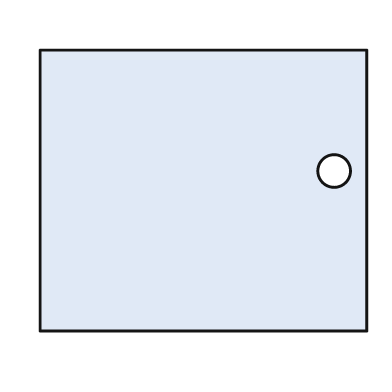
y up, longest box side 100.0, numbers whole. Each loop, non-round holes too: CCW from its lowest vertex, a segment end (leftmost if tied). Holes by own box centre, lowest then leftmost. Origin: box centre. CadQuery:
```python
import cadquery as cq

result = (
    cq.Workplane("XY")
    .moveTo(-50.0, -43.0)
    .lineTo(50.0, -43.0)
    .lineTo(50.0, 43.0)
    .lineTo(-50.0, 43.0)
    .close()
    .moveTo(40.0, 6.0)
    .circle(5.0)
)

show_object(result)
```